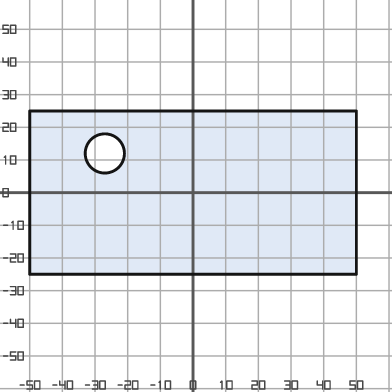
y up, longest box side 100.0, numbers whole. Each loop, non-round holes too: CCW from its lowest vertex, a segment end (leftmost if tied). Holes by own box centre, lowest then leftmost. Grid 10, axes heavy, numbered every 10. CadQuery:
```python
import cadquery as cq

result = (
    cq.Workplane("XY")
    .moveTo(-50.0, -25.0)
    .lineTo(50.0, -25.0)
    .lineTo(50.0, 25.0)
    .lineTo(-50.0, 25.0)
    .close()
    .moveTo(-27.0, 12.0)
    .circle(6.0)
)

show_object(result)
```